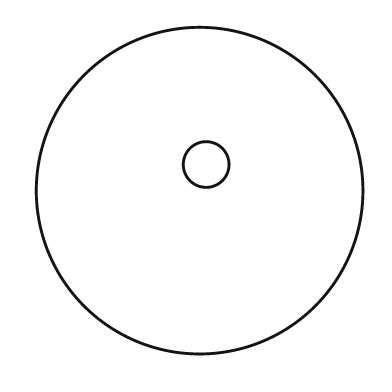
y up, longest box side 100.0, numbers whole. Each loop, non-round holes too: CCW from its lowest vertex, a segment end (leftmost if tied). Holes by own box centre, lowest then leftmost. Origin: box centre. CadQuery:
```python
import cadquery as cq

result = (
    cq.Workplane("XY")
    .moveTo(0.0, 0.0)
    .circle(50.0)
    .moveTo(2.0, 8.0)
    .circle(7.0)
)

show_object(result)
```